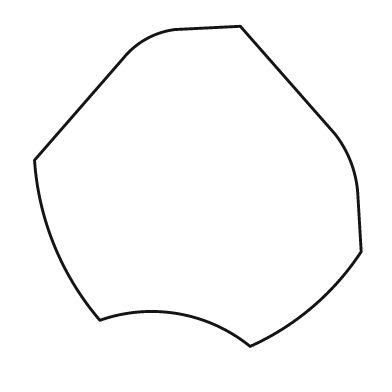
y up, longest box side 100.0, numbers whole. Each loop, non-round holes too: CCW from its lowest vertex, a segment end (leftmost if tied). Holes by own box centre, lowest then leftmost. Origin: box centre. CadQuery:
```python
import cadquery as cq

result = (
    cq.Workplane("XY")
    .moveTo(16.0, -49.0)
    .threePointArc((35.0, -37.0), (50.0, -20.0))
    .lineTo(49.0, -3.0)
    .threePointArc((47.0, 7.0), (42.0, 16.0))
    .lineTo(13.0, 49.0)
    .lineTo(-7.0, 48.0)
    .threePointArc((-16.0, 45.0), (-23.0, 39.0))
    .lineTo(-50.0, 8.0)
    .threePointArc((-44.0, -18.0), (-30.0, -41.0))
    .threePointArc((-6.0, -39.0), (16.0, -49.0))
    .close()
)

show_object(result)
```